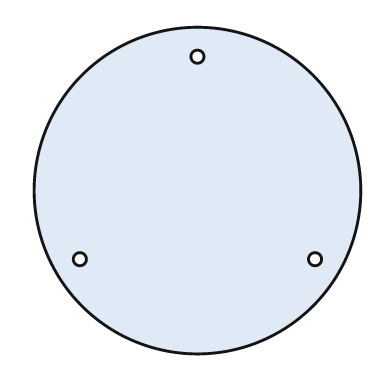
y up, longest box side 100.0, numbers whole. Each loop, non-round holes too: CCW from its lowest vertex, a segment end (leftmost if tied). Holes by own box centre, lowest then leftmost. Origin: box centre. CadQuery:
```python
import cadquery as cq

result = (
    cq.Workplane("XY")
    .moveTo(0.0, 0.0)
    .circle(50.0)
    .moveTo(-36.0, -21.0)
    .circle(2.0)
    .moveTo(36.0, -21.0)
    .circle(2.0)
    .moveTo(0.0, 41.0)
    .circle(2.0)
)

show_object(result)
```